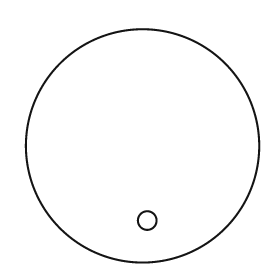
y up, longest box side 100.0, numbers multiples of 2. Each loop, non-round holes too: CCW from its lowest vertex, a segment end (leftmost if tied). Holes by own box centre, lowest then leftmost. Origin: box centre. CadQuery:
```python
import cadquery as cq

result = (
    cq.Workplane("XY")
    .moveTo(0.0, 0.0)
    .circle(50.0)
    .moveTo(2.0, -32.0)
    .circle(4.0)
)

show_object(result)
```